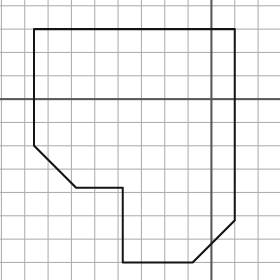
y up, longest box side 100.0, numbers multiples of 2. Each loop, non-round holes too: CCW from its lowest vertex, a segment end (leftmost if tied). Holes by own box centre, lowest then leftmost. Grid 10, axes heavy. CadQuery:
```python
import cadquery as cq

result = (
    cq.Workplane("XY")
    .moveTo(-38.0, -70.0)
    .lineTo(-8.0, -70.0)
    .lineTo(10.0, -52.0)
    .lineTo(10.0, 30.0)
    .lineTo(-76.0, 30.0)
    .lineTo(-76.0, -20.0)
    .lineTo(-58.0, -38.0)
    .lineTo(-38.0, -38.0)
    .close()
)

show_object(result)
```